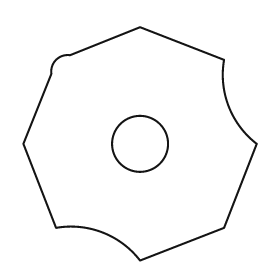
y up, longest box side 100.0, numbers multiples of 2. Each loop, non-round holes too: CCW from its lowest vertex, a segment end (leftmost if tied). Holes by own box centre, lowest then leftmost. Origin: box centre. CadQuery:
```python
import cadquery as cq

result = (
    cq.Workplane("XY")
    .moveTo(0.0, -50.0)
    .lineTo(36.0, -36.0)
    .lineTo(50.0, 0.0)
    .threePointArc((38.0, 16.0), (36.0, 36.0))
    .lineTo(0.0, 50.0)
    .lineTo(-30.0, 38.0)
    .threePointArc((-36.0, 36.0), (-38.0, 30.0))
    .lineTo(-50.0, 0.0)
    .lineTo(-36.0, -36.0)
    .threePointArc((-16.0, -38.0), (0.0, -50.0))
    .close()
    .moveTo(0.0, 0.0)
    .circle(12.0)
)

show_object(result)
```